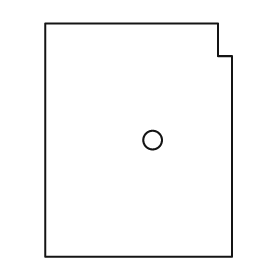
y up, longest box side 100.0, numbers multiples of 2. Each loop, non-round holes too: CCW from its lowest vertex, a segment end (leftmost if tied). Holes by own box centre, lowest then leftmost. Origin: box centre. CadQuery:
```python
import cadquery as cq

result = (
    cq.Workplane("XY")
    .moveTo(-40.0, -50.0)
    .lineTo(40.0, -50.0)
    .lineTo(40.0, 36.0)
    .lineTo(34.0, 36.0)
    .lineTo(34.0, 50.0)
    .lineTo(-40.0, 50.0)
    .close()
    .moveTo(6.0, 0.0)
    .circle(4.0)
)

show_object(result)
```